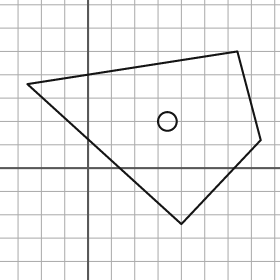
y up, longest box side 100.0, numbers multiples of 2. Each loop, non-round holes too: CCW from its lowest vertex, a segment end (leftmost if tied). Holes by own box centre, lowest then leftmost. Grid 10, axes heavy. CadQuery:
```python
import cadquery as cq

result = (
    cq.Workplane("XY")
    .moveTo(40.0, -24.0)
    .lineTo(74.0, 12.0)
    .lineTo(64.0, 50.0)
    .lineTo(-26.0, 36.0)
    .close()
    .moveTo(34.0, 20.0)
    .circle(4.0)
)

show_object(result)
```